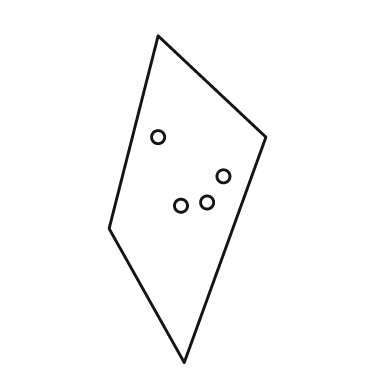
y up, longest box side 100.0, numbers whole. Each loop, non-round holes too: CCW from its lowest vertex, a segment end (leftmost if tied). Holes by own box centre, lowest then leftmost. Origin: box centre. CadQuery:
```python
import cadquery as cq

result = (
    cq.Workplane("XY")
    .moveTo(-1.0, -50.0)
    .lineTo(24.0, 19.0)
    .lineTo(-9.0, 50.0)
    .lineTo(-24.0, -9.0)
    .close()
    .moveTo(-2.0, -2.0)
    .circle(2.0)
    .moveTo(6.0, -1.0)
    .circle(2.0)
    .moveTo(11.0, 7.0)
    .circle(2.0)
    .moveTo(-9.0, 19.0)
    .circle(2.0)
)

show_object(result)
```